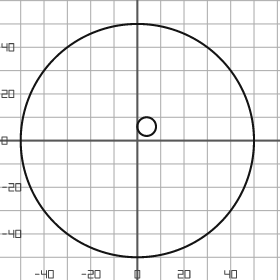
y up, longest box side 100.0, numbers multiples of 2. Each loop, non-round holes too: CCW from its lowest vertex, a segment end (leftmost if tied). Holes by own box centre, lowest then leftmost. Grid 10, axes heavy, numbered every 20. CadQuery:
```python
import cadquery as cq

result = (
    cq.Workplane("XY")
    .moveTo(0.0, 0.0)
    .circle(50.0)
    .moveTo(4.0, 6.0)
    .circle(4.0)
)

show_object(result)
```